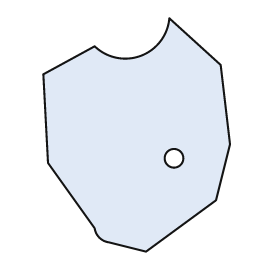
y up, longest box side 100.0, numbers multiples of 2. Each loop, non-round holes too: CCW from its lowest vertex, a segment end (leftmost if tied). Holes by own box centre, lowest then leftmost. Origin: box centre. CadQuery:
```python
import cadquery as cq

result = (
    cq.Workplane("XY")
    .moveTo(4.0, -50.0)
    .lineTo(34.0, -28.0)
    .lineTo(40.0, -4.0)
    .lineTo(36.0, 30.0)
    .lineTo(14.0, 50.0)
    .threePointArc((2.0, 34.0), (-18.0, 38.0))
    .lineTo(-40.0, 26.0)
    .lineTo(-38.0, -12.0)
    .lineTo(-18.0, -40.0)
    .threePointArc((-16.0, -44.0), (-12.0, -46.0))
    .close()
    .moveTo(16.0, -10.0)
    .circle(4.0)
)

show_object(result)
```